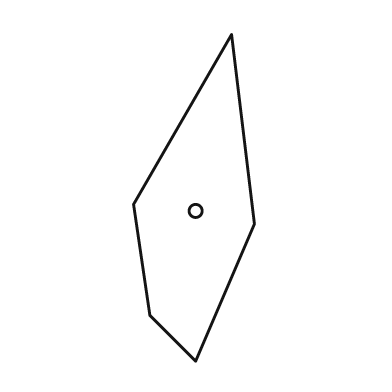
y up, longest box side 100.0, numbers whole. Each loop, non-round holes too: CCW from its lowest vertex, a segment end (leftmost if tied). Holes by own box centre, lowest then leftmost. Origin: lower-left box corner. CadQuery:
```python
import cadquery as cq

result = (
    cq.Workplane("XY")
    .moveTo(19.0, 0.0)
    .lineTo(37.0, 42.0)
    .lineTo(30.0, 100.0)
    .lineTo(0.0, 48.0)
    .lineTo(5.0, 14.0)
    .close()
    .moveTo(19.0, 46.0)
    .circle(2.0)
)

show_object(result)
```